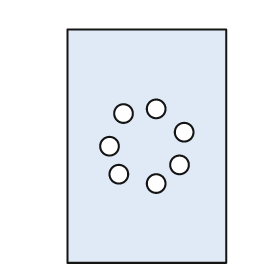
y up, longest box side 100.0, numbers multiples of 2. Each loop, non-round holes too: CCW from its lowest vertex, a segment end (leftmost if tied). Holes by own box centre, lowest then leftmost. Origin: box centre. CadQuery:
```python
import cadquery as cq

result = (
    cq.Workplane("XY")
    .moveTo(-34.0, -50.0)
    .lineTo(34.0, -50.0)
    .lineTo(34.0, 50.0)
    .lineTo(-34.0, 50.0)
    .close()
    .moveTo(4.0, -16.0)
    .circle(4.0)
    .moveTo(-12.0, -12.0)
    .circle(4.0)
    .moveTo(14.0, -8.0)
    .circle(4.0)
    .moveTo(-16.0, 0.0)
    .circle(4.0)
    .moveTo(16.0, 6.0)
    .circle(4.0)
    .moveTo(-10.0, 14.0)
    .circle(4.0)
    .moveTo(4.0, 16.0)
    .circle(4.0)
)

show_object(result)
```